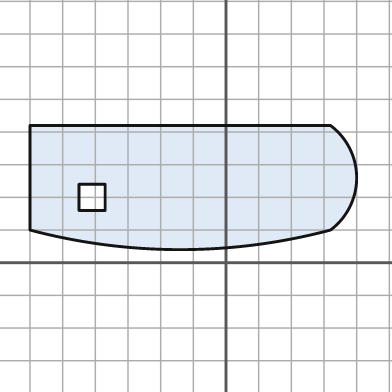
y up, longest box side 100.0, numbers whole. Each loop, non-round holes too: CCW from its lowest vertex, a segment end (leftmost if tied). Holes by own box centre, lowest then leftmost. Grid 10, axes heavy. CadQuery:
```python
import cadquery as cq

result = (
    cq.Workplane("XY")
    .moveTo(-60.0, 10.0)
    .threePointArc((-14.0, 4.0), (32.0, 10.0))
    .threePointArc((40.0, 26.0), (32.0, 42.0))
    .lineTo(-60.0, 42.0)
    .close()
    .moveTo(-45.0, 16.0)
    .lineTo(-37.0, 16.0)
    .lineTo(-37.0, 24.0)
    .lineTo(-45.0, 24.0)
    .close()
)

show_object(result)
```